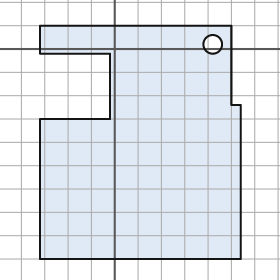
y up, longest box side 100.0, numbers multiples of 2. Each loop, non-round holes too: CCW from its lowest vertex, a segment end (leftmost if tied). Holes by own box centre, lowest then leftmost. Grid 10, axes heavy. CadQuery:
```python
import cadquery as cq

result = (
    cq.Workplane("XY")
    .moveTo(-32.0, -90.0)
    .lineTo(54.0, -90.0)
    .lineTo(54.0, -24.0)
    .lineTo(50.0, -24.0)
    .lineTo(50.0, 10.0)
    .lineTo(-32.0, 10.0)
    .lineTo(-32.0, -2.0)
    .lineTo(-2.0, -2.0)
    .lineTo(-2.0, -30.0)
    .lineTo(-32.0, -30.0)
    .close()
    .moveTo(42.0, 2.0)
    .circle(4.0)
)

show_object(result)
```